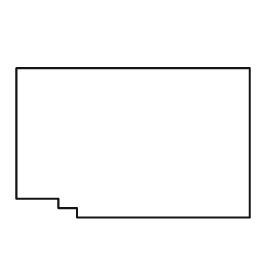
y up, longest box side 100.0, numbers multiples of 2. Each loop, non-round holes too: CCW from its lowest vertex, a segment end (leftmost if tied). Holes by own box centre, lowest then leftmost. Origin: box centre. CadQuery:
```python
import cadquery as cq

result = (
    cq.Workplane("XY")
    .moveTo(-24.0, -32.0)
    .lineTo(50.0, -32.0)
    .lineTo(50.0, 32.0)
    .lineTo(-50.0, 32.0)
    .lineTo(-50.0, -24.0)
    .lineTo(-32.0, -24.0)
    .lineTo(-32.0, -28.0)
    .lineTo(-24.0, -28.0)
    .close()
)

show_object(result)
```